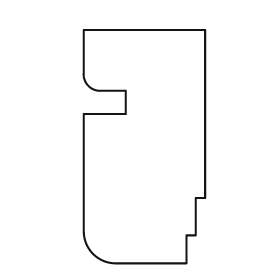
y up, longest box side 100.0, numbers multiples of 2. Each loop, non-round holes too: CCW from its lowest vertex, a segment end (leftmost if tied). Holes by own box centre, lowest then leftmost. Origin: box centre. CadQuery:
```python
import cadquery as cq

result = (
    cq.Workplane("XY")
    .moveTo(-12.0, -50.0)
    .lineTo(18.0, -50.0)
    .lineTo(18.0, -38.0)
    .lineTo(22.0, -38.0)
    .lineTo(22.0, -22.0)
    .lineTo(26.0, -22.0)
    .lineTo(26.0, 50.0)
    .lineTo(-26.0, 50.0)
    .lineTo(-26.0, 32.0)
    .threePointArc((-24.0, 26.0), (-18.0, 24.0))
    .lineTo(-8.0, 24.0)
    .lineTo(-8.0, 14.0)
    .lineTo(-26.0, 14.0)
    .lineTo(-26.0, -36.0)
    .threePointArc((-22.0, -46.0), (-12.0, -50.0))
    .close()
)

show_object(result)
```